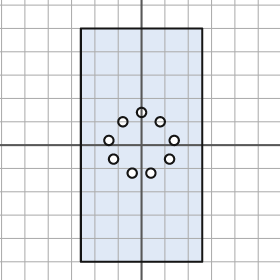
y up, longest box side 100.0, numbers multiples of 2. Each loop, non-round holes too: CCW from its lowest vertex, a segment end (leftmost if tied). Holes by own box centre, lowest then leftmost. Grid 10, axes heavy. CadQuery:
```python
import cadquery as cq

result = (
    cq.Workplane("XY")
    .moveTo(-26.0, -50.0)
    .lineTo(26.0, -50.0)
    .lineTo(26.0, 50.0)
    .lineTo(-26.0, 50.0)
    .close()
    .moveTo(-4.0, -12.0)
    .circle(2.0)
    .moveTo(4.0, -12.0)
    .circle(2.0)
    .moveTo(-12.0, -6.0)
    .circle(2.0)
    .moveTo(12.0, -6.0)
    .circle(2.0)
    .moveTo(-14.0, 2.0)
    .circle(2.0)
    .moveTo(14.0, 2.0)
    .circle(2.0)
    .moveTo(-8.0, 10.0)
    .circle(2.0)
    .moveTo(8.0, 10.0)
    .circle(2.0)
    .moveTo(0.0, 14.0)
    .circle(2.0)
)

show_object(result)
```